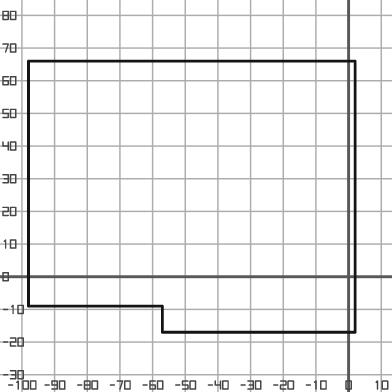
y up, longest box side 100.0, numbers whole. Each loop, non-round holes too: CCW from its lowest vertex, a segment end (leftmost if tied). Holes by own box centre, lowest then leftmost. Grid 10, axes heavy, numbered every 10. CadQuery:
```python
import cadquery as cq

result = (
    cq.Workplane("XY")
    .moveTo(-57.0, -17.0)
    .lineTo(2.0, -17.0)
    .lineTo(2.0, 66.0)
    .lineTo(-98.0, 66.0)
    .lineTo(-98.0, -9.0)
    .lineTo(-57.0, -9.0)
    .close()
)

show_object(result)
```